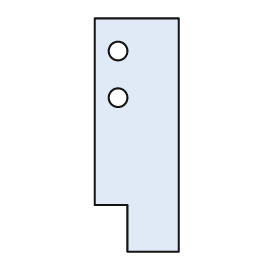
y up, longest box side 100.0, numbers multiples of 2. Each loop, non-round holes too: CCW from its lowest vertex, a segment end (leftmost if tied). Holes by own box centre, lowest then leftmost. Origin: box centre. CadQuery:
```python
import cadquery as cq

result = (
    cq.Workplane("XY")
    .moveTo(-4.0, -50.0)
    .lineTo(18.0, -50.0)
    .lineTo(18.0, 50.0)
    .lineTo(-18.0, 50.0)
    .lineTo(-18.0, -30.0)
    .lineTo(-4.0, -30.0)
    .close()
    .moveTo(-8.0, 16.0)
    .circle(4.0)
    .moveTo(-8.0, 36.0)
    .circle(4.0)
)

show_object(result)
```